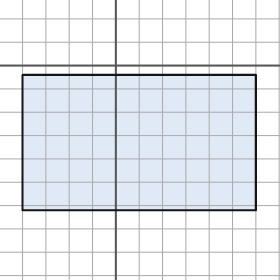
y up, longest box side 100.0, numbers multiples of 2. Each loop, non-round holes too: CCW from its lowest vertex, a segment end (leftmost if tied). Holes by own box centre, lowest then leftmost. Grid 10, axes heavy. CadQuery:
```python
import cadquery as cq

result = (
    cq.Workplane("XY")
    .moveTo(-40.0, -62.0)
    .lineTo(60.0, -62.0)
    .lineTo(60.0, -4.0)
    .lineTo(-40.0, -4.0)
    .close()
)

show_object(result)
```